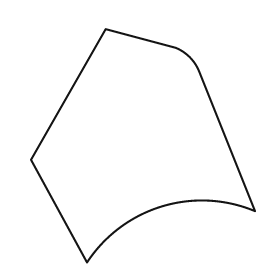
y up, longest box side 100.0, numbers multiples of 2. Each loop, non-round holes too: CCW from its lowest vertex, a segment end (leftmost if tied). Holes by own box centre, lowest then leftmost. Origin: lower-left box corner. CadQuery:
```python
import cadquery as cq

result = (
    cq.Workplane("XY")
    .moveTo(24.0, 0.0)
    .threePointArc((56.0, 24.0), (96.0, 22.0))
    .lineTo(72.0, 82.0)
    .threePointArc((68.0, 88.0), (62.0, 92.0))
    .lineTo(32.0, 100.0)
    .lineTo(0.0, 44.0)
    .close()
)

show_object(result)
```